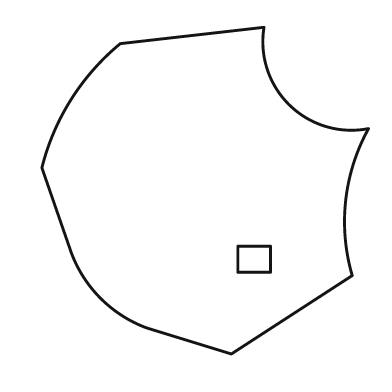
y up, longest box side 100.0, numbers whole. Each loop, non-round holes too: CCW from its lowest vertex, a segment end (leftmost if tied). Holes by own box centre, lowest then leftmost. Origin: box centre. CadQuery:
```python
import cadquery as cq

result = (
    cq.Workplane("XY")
    .moveTo(8.0, -50.0)
    .lineTo(45.0, -26.0)
    .threePointArc((43.0, -3.0), (50.0, 19.0))
    .threePointArc((26.0, 26.0), (18.0, 50.0))
    .lineTo(-26.0, 45.0)
    .threePointArc((-41.0, 28.0), (-50.0, 7.0))
    .lineTo(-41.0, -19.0)
    .threePointArc((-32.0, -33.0), (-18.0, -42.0))
    .close()
    .moveTo(10.0, -25.0)
    .lineTo(20.0, -25.0)
    .lineTo(20.0, -17.0)
    .lineTo(10.0, -17.0)
    .close()
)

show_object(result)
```